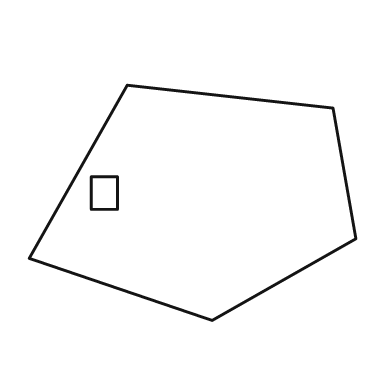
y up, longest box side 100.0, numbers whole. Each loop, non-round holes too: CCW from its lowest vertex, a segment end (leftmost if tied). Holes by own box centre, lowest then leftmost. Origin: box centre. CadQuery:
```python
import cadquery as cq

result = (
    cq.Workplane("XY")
    .moveTo(6.0, -36.0)
    .lineTo(50.0, -11.0)
    .lineTo(43.0, 29.0)
    .lineTo(-20.0, 36.0)
    .lineTo(-50.0, -17.0)
    .close()
    .moveTo(-31.0, -2.0)
    .lineTo(-23.0, -2.0)
    .lineTo(-23.0, 8.0)
    .lineTo(-31.0, 8.0)
    .close()
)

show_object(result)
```